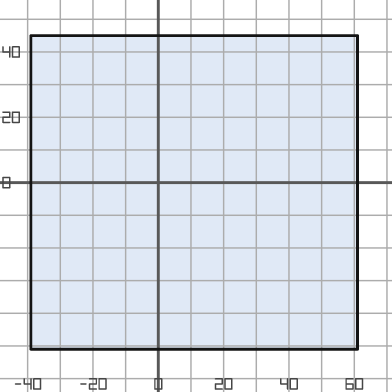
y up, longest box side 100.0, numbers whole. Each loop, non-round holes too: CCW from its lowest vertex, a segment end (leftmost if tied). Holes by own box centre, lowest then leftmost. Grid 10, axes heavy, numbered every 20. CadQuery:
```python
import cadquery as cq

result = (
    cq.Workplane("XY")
    .moveTo(-39.0, -51.0)
    .lineTo(61.0, -51.0)
    .lineTo(61.0, 45.0)
    .lineTo(-39.0, 45.0)
    .close()
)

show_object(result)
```